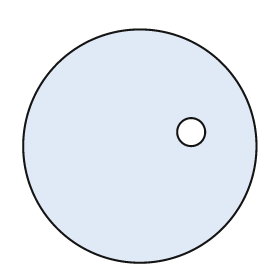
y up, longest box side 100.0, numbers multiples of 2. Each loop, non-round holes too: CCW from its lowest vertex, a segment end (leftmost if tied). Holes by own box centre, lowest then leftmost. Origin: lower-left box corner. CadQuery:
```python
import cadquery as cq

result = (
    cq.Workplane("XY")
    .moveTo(50.0, 50.0)
    .circle(50.0)
    .moveTo(72.0, 56.0)
    .circle(6.0)
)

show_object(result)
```